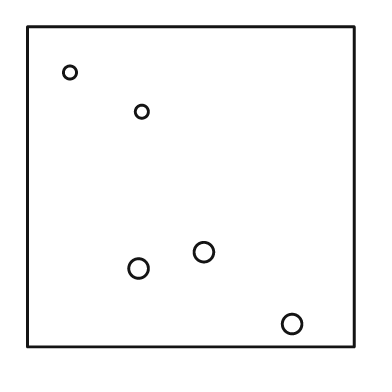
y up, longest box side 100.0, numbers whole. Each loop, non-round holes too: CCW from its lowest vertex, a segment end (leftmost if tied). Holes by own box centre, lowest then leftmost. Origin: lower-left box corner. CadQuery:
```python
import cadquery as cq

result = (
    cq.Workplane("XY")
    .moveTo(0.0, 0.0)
    .lineTo(100.0, 0.0)
    .lineTo(100.0, 98.0)
    .lineTo(0.0, 98.0)
    .close()
    .moveTo(81.0, 7.0)
    .circle(3.0)
    .moveTo(34.0, 24.0)
    .circle(3.0)
    .moveTo(54.0, 29.0)
    .circle(3.0)
    .moveTo(35.0, 72.0)
    .circle(2.0)
    .moveTo(13.0, 84.0)
    .circle(2.0)
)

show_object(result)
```